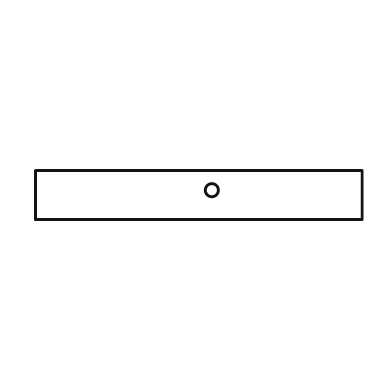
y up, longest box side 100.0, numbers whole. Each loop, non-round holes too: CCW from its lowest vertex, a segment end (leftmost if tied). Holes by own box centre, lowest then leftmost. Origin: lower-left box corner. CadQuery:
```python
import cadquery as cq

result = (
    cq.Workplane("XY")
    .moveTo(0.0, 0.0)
    .lineTo(100.0, 0.0)
    .lineTo(100.0, 15.0)
    .lineTo(0.0, 15.0)
    .close()
    .moveTo(54.0, 9.0)
    .circle(2.0)
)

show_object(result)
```